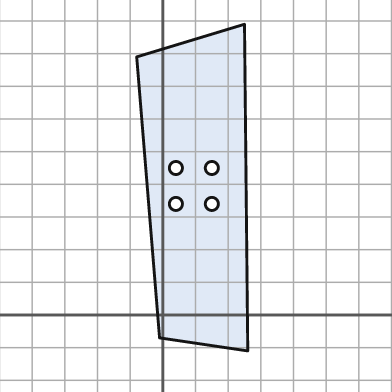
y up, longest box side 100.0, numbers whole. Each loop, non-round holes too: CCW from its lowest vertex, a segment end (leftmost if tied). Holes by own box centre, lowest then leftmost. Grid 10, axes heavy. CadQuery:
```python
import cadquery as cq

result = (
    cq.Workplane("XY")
    .moveTo(26.0, -11.0)
    .lineTo(25.0, 89.0)
    .lineTo(-8.0, 79.0)
    .lineTo(-1.0, -7.0)
    .close()
    .moveTo(4.0, 34.0)
    .circle(2.0)
    .moveTo(15.0, 34.0)
    .circle(2.0)
    .moveTo(4.0, 45.0)
    .circle(2.0)
    .moveTo(15.0, 45.0)
    .circle(2.0)
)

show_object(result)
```